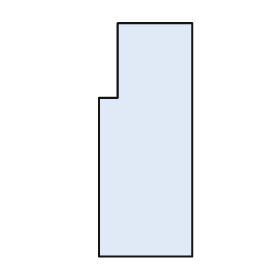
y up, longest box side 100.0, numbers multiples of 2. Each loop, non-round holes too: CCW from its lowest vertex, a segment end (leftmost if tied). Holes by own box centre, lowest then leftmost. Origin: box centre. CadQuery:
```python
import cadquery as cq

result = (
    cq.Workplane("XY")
    .moveTo(-20.0, -50.0)
    .lineTo(20.0, -50.0)
    .lineTo(20.0, 50.0)
    .lineTo(-12.0, 50.0)
    .lineTo(-12.0, 18.0)
    .lineTo(-20.0, 18.0)
    .close()
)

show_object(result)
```